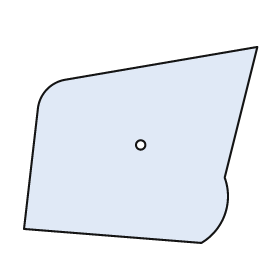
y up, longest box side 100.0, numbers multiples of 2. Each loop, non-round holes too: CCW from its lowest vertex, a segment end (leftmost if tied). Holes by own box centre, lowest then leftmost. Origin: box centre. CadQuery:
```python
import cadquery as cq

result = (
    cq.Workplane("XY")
    .moveTo(26.0, -42.0)
    .threePointArc((36.0, -30.0), (36.0, -14.0))
    .lineTo(50.0, 42.0)
    .lineTo(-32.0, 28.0)
    .threePointArc((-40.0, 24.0), (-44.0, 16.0))
    .lineTo(-50.0, -36.0)
    .close()
    .moveTo(0.0, 0.0)
    .circle(2.0)
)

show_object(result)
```